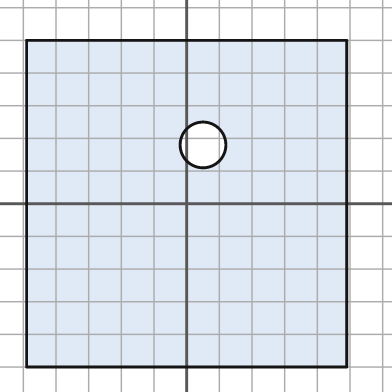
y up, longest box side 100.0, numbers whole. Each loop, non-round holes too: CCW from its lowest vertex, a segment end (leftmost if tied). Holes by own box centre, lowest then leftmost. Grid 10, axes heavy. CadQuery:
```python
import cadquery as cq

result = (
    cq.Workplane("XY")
    .moveTo(-49.0, -50.0)
    .lineTo(49.0, -50.0)
    .lineTo(49.0, 50.0)
    .lineTo(-49.0, 50.0)
    .close()
    .moveTo(5.0, 18.0)
    .circle(7.0)
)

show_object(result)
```